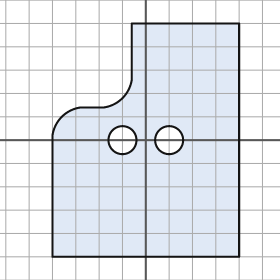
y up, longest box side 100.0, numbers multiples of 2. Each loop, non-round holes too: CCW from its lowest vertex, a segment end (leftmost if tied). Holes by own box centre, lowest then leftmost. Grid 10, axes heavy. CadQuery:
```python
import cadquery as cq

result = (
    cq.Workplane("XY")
    .moveTo(-40.0, -50.0)
    .lineTo(40.0, -50.0)
    .lineTo(40.0, 50.0)
    .lineTo(-6.0, 50.0)
    .lineTo(-6.0, 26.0)
    .threePointArc((-10.0, 18.0), (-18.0, 14.0))
    .lineTo(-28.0, 14.0)
    .threePointArc((-36.0, 10.0), (-40.0, 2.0))
    .close()
    .moveTo(-10.0, 0.0)
    .circle(6.0)
    .moveTo(10.0, 0.0)
    .circle(6.0)
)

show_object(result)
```